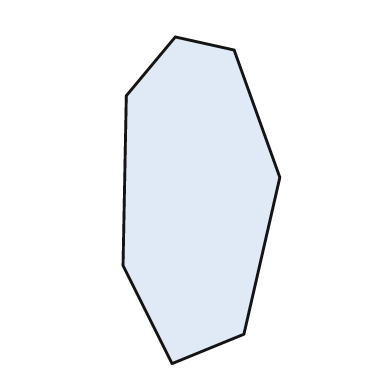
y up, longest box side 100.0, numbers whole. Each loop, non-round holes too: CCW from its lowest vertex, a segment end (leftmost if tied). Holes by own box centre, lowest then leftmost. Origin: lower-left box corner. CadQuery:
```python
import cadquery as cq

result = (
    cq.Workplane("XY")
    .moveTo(15.0, 0.0)
    .lineTo(37.0, 9.0)
    .lineTo(48.0, 57.0)
    .lineTo(34.0, 96.0)
    .lineTo(16.0, 100.0)
    .lineTo(1.0, 82.0)
    .lineTo(0.0, 30.0)
    .close()
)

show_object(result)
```